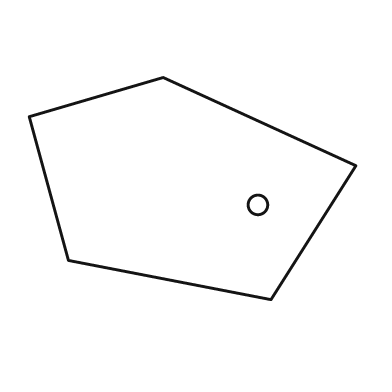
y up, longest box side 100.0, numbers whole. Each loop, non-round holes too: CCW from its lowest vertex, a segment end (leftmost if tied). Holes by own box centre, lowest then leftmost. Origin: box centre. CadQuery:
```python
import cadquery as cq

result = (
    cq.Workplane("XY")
    .moveTo(24.0, -34.0)
    .lineTo(50.0, 7.0)
    .lineTo(-9.0, 34.0)
    .lineTo(-50.0, 22.0)
    .lineTo(-38.0, -22.0)
    .close()
    .moveTo(20.0, -5.0)
    .circle(3.0)
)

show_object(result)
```